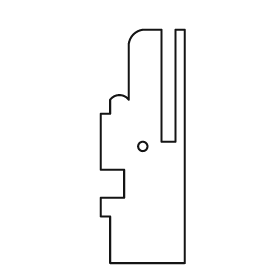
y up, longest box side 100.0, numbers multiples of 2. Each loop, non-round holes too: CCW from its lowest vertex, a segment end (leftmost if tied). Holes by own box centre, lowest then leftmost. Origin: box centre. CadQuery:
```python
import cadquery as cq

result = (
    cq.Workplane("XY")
    .moveTo(-14.0, -50.0)
    .lineTo(18.0, -50.0)
    .lineTo(18.0, 50.0)
    .lineTo(14.0, 50.0)
    .lineTo(14.0, 2.0)
    .lineTo(8.0, 2.0)
    .lineTo(8.0, 50.0)
    .lineTo(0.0, 50.0)
    .threePointArc((-4.0, 48.0), (-6.0, 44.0))
    .lineTo(-6.0, 20.0)
    .threePointArc((-10.0, 22.0), (-14.0, 20.0))
    .lineTo(-14.0, 14.0)
    .lineTo(-18.0, 14.0)
    .lineTo(-18.0, -10.0)
    .lineTo(-8.0, -10.0)
    .lineTo(-8.0, -22.0)
    .lineTo(-18.0, -22.0)
    .lineTo(-18.0, -30.0)
    .lineTo(-14.0, -30.0)
    .close()
    .moveTo(0.0, 0.0)
    .circle(2.0)
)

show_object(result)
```